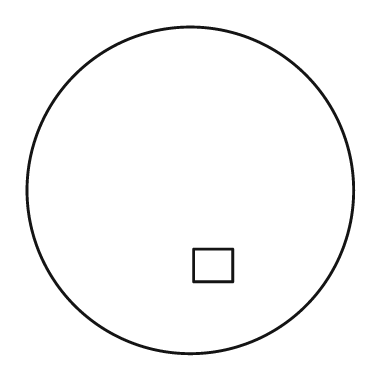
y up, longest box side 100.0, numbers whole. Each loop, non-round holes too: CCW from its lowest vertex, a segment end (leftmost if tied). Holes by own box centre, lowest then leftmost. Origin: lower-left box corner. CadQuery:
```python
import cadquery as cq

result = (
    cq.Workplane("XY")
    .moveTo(50.0, 50.0)
    .circle(50.0)
    .moveTo(51.0, 22.0)
    .lineTo(63.0, 22.0)
    .lineTo(63.0, 32.0)
    .lineTo(51.0, 32.0)
    .close()
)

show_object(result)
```